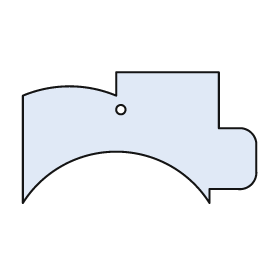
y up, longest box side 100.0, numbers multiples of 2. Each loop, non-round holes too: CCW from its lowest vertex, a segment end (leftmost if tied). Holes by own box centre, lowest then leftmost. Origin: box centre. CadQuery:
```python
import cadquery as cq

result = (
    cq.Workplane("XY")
    .moveTo(-50.0, -28.0)
    .threePointArc((-10.0, -6.0), (30.0, -28.0))
    .lineTo(30.0, -22.0)
    .lineTo(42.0, -22.0)
    .threePointArc((48.0, -20.0), (50.0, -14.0))
    .lineTo(50.0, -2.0)
    .threePointArc((48.0, 2.0), (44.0, 4.0))
    .lineTo(34.0, 4.0)
    .lineTo(34.0, 28.0)
    .lineTo(-10.0, 28.0)
    .lineTo(-10.0, 18.0)
    .threePointArc((-30.0, 22.0), (-50.0, 18.0))
    .close()
    .moveTo(-8.0, 12.0)
    .circle(2.0)
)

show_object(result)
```